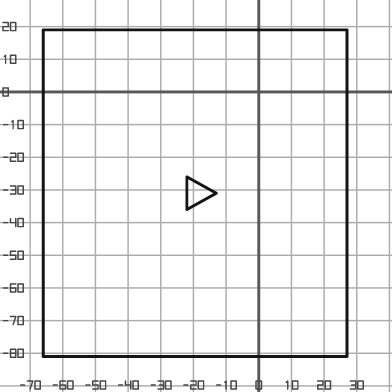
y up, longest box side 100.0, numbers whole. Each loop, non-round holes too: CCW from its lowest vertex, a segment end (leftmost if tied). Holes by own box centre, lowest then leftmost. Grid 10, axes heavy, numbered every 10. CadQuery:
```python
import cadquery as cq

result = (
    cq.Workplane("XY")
    .moveTo(-66.0, -81.0)
    .lineTo(27.0, -81.0)
    .lineTo(27.0, 19.0)
    .lineTo(-66.0, 19.0)
    .close()
    .moveTo(-22.0, -36.0)
    .lineTo(-13.0, -31.0)
    .lineTo(-22.0, -26.0)
    .close()
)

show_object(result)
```